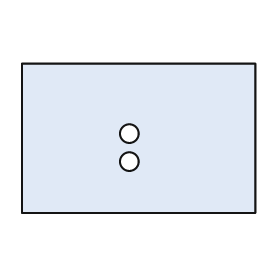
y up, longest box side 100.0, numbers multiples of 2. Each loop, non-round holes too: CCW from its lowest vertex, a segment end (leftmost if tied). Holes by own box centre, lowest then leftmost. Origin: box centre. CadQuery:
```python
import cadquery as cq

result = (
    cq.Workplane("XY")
    .moveTo(-50.0, -32.0)
    .lineTo(50.0, -32.0)
    .lineTo(50.0, 32.0)
    .lineTo(-50.0, 32.0)
    .close()
    .moveTo(-4.0, -10.0)
    .circle(4.0)
    .moveTo(-4.0, 2.0)
    .circle(4.0)
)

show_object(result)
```